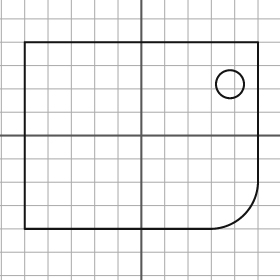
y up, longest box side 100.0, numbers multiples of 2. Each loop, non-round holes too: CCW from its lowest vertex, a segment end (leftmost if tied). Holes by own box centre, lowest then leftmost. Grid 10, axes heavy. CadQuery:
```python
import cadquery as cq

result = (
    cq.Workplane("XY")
    .moveTo(-50.0, -40.0)
    .lineTo(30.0, -40.0)
    .threePointArc((44.0, -34.0), (50.0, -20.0))
    .lineTo(50.0, 40.0)
    .lineTo(-50.0, 40.0)
    .close()
    .moveTo(38.0, 22.0)
    .circle(6.0)
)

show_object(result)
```